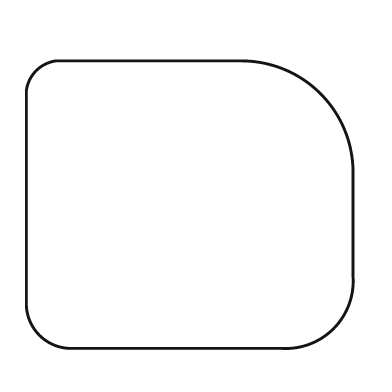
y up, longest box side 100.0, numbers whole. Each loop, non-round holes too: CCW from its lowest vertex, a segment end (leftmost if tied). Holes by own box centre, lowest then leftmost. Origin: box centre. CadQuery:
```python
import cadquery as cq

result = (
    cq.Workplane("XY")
    .moveTo(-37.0, -44.0)
    .lineTo(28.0, -44.0)
    .threePointArc((44.0, -38.0), (50.0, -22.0))
    .lineTo(50.0, 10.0)
    .threePointArc((40.0, 34.0), (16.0, 44.0))
    .lineTo(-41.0, 44.0)
    .threePointArc((-47.0, 41.0), (-50.0, 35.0))
    .lineTo(-50.0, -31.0)
    .threePointArc((-46.0, -40.0), (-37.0, -44.0))
    .close()
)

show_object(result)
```